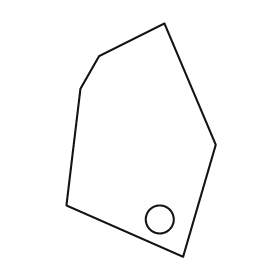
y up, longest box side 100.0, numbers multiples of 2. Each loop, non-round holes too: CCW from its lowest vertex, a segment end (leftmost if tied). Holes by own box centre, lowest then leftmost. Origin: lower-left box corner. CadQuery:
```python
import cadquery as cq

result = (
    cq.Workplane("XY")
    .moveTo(50.0, 0.0)
    .lineTo(64.0, 48.0)
    .lineTo(42.0, 100.0)
    .lineTo(14.0, 86.0)
    .lineTo(6.0, 72.0)
    .lineTo(0.0, 22.0)
    .close()
    .moveTo(40.0, 16.0)
    .circle(6.0)
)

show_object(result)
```